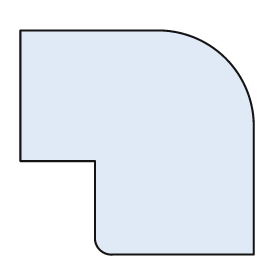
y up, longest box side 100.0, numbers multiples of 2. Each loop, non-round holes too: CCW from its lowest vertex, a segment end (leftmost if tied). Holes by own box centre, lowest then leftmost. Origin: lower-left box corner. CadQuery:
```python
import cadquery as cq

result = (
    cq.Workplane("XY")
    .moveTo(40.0, 0.0)
    .lineTo(100.0, 0.0)
    .lineTo(100.0, 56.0)
    .threePointArc((88.0, 84.0), (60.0, 96.0))
    .lineTo(0.0, 96.0)
    .lineTo(0.0, 40.0)
    .lineTo(32.0, 40.0)
    .lineTo(32.0, 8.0)
    .threePointArc((34.0, 2.0), (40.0, 0.0))
    .close()
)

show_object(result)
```